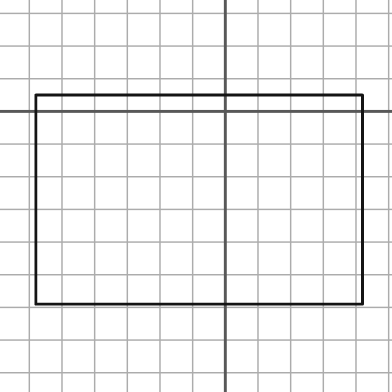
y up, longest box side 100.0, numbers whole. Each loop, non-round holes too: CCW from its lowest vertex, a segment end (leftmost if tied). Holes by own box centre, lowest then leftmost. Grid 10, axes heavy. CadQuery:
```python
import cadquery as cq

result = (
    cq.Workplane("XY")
    .moveTo(-58.0, -59.0)
    .lineTo(42.0, -59.0)
    .lineTo(42.0, 5.0)
    .lineTo(-58.0, 5.0)
    .close()
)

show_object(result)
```